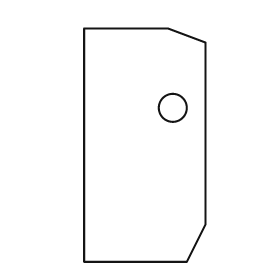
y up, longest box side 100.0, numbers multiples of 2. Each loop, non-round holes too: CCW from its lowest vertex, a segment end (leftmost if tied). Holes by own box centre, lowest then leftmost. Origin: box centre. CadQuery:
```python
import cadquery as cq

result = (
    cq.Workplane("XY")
    .moveTo(-26.0, -50.0)
    .lineTo(18.0, -50.0)
    .lineTo(26.0, -34.0)
    .lineTo(26.0, 44.0)
    .lineTo(10.0, 50.0)
    .lineTo(-26.0, 50.0)
    .close()
    .moveTo(12.0, 16.0)
    .circle(6.0)
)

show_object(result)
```